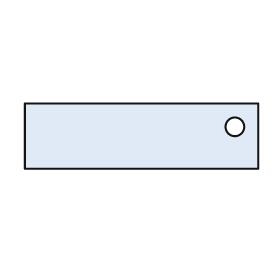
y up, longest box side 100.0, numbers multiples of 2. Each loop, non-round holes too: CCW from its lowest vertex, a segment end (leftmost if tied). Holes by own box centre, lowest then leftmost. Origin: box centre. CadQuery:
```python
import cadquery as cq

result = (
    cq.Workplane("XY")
    .moveTo(-50.0, -14.0)
    .lineTo(50.0, -14.0)
    .lineTo(50.0, 14.0)
    .lineTo(-50.0, 14.0)
    .close()
    .moveTo(40.0, 4.0)
    .circle(4.0)
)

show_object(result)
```